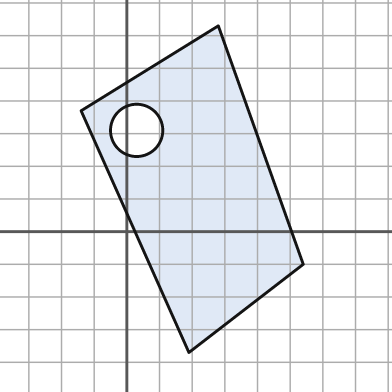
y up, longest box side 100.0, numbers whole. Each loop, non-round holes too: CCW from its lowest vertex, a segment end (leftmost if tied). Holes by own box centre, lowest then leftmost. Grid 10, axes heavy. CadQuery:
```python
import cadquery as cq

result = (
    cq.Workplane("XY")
    .moveTo(19.0, -37.0)
    .lineTo(54.0, -10.0)
    .lineTo(28.0, 63.0)
    .lineTo(-14.0, 37.0)
    .close()
    .moveTo(3.0, 31.0)
    .circle(8.0)
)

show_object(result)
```